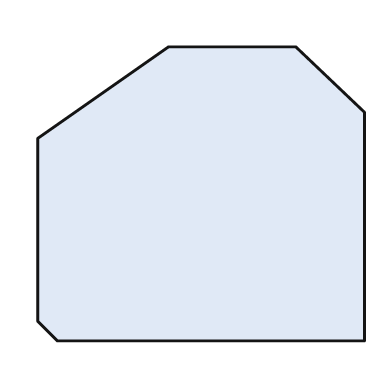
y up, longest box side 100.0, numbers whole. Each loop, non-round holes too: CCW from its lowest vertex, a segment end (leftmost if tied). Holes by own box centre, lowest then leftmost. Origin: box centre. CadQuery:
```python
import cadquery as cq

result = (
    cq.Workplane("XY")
    .moveTo(-44.0, -45.0)
    .lineTo(50.0, -45.0)
    .lineTo(50.0, 25.0)
    .lineTo(29.0, 45.0)
    .lineTo(-10.0, 45.0)
    .lineTo(-50.0, 17.0)
    .lineTo(-50.0, -39.0)
    .close()
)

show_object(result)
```